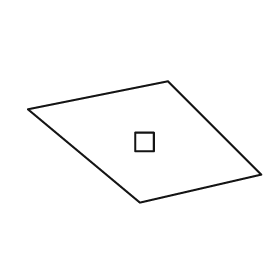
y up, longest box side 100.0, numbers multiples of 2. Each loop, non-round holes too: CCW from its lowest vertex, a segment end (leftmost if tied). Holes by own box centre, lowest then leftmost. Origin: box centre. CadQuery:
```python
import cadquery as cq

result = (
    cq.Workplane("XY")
    .moveTo(-2.0, -26.0)
    .lineTo(50.0, -14.0)
    .lineTo(10.0, 26.0)
    .lineTo(-50.0, 14.0)
    .close()
    .moveTo(-4.0, -4.0)
    .lineTo(4.0, -4.0)
    .lineTo(4.0, 4.0)
    .lineTo(-4.0, 4.0)
    .close()
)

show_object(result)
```